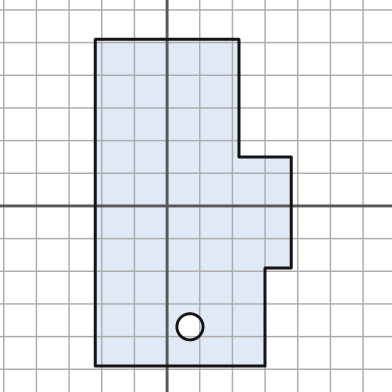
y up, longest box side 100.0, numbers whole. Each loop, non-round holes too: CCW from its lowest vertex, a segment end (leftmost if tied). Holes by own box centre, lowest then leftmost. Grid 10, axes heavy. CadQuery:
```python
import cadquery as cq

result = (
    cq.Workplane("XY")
    .moveTo(-22.0, -49.0)
    .lineTo(30.0, -49.0)
    .lineTo(30.0, -19.0)
    .lineTo(38.0, -19.0)
    .lineTo(38.0, 15.0)
    .lineTo(22.0, 15.0)
    .lineTo(22.0, 51.0)
    .lineTo(-22.0, 51.0)
    .close()
    .moveTo(7.0, -37.0)
    .circle(4.0)
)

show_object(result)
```